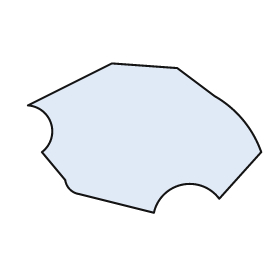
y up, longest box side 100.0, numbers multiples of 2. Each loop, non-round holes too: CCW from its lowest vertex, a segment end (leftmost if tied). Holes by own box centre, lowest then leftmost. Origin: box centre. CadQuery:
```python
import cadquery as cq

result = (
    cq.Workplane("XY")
    .moveTo(4.0, -32.0)
    .threePointArc((16.0, -20.0), (32.0, -26.0))
    .lineTo(50.0, -6.0)
    .threePointArc((42.0, 8.0), (30.0, 18.0))
    .lineTo(14.0, 30.0)
    .lineTo(-14.0, 32.0)
    .lineTo(-50.0, 14.0)
    .threePointArc((-40.0, 6.0), (-44.0, -6.0))
    .lineTo(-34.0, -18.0)
    .threePointArc((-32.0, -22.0), (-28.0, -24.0))
    .close()
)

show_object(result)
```